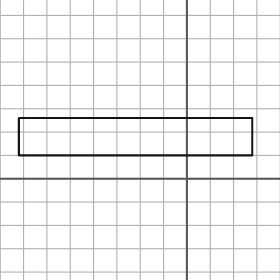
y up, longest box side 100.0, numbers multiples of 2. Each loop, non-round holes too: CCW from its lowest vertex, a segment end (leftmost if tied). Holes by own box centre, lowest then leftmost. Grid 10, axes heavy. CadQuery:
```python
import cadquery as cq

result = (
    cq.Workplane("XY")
    .moveTo(-72.0, 10.0)
    .lineTo(28.0, 10.0)
    .lineTo(28.0, 26.0)
    .lineTo(-72.0, 26.0)
    .close()
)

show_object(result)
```